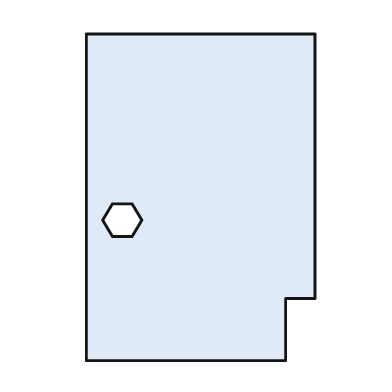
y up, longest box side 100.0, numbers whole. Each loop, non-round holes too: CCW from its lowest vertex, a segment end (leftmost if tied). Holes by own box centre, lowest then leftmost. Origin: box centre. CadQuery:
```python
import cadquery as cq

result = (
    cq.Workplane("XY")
    .moveTo(-35.0, -50.0)
    .lineTo(26.0, -50.0)
    .lineTo(26.0, -31.0)
    .lineTo(35.0, -31.0)
    .lineTo(35.0, 50.0)
    .lineTo(-35.0, 50.0)
    .close()
    .moveTo(-27.0, -12.0)
    .lineTo(-21.0, -12.0)
    .lineTo(-18.0, -7.0)
    .lineTo(-21.0, -2.0)
    .lineTo(-27.0, -2.0)
    .lineTo(-30.0, -7.0)
    .close()
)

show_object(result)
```